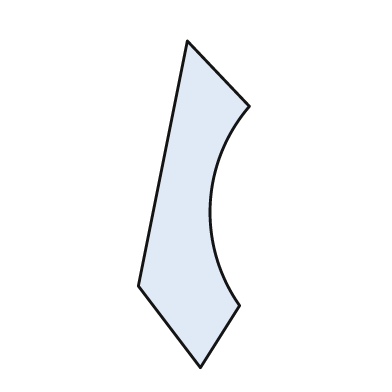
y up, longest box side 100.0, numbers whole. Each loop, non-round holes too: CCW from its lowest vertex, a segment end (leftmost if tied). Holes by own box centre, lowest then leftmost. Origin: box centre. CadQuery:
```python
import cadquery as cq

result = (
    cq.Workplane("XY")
    .moveTo(2.0, -50.0)
    .lineTo(14.0, -31.0)
    .threePointArc((5.0, 0.0), (17.0, 30.0))
    .lineTo(-2.0, 50.0)
    .lineTo(-17.0, -25.0)
    .close()
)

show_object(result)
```